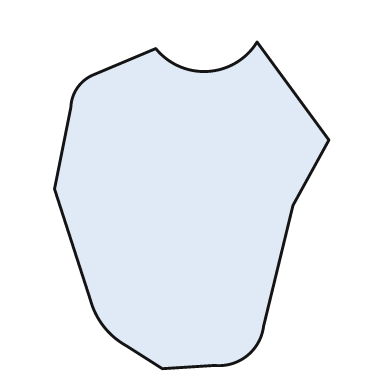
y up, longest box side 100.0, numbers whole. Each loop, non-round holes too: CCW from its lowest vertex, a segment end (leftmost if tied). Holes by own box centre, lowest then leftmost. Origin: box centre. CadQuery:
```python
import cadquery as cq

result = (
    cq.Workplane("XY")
    .moveTo(-9.0, -50.0)
    .lineTo(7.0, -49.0)
    .threePointArc((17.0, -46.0), (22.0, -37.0))
    .lineTo(31.0, 0.0)
    .lineTo(42.0, 20.0)
    .lineTo(20.0, 50.0)
    .threePointArc((5.0, 41.0), (-11.0, 48.0))
    .lineTo(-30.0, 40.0)
    .threePointArc((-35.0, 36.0), (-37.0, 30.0))
    .lineTo(-42.0, 5.0)
    .lineTo(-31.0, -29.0)
    .threePointArc((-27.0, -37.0), (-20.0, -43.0))
    .close()
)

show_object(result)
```